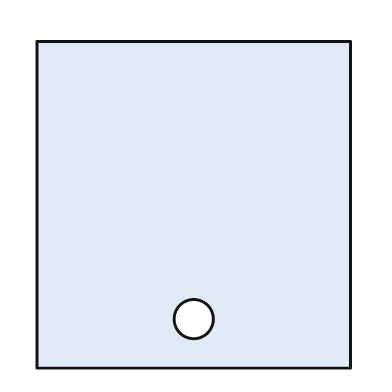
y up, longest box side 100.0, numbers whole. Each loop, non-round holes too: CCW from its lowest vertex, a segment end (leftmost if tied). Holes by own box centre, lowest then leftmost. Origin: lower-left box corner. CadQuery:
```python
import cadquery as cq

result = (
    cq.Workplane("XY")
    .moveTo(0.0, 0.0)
    .lineTo(96.0, 0.0)
    .lineTo(96.0, 100.0)
    .lineTo(0.0, 100.0)
    .close()
    .moveTo(48.0, 15.0)
    .circle(6.0)
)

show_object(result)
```